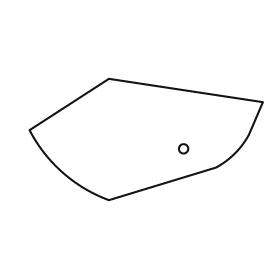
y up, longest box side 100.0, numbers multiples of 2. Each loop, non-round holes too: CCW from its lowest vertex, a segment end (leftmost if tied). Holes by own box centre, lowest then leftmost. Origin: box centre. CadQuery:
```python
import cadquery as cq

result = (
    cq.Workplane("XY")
    .moveTo(-16.0, -26.0)
    .lineTo(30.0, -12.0)
    .threePointArc((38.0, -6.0), (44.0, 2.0))
    .lineTo(50.0, 16.0)
    .lineTo(-16.0, 26.0)
    .lineTo(-50.0, 4.0)
    .threePointArc((-36.0, -14.0), (-16.0, -26.0))
    .close()
    .moveTo(16.0, -4.0)
    .circle(2.0)
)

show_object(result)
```